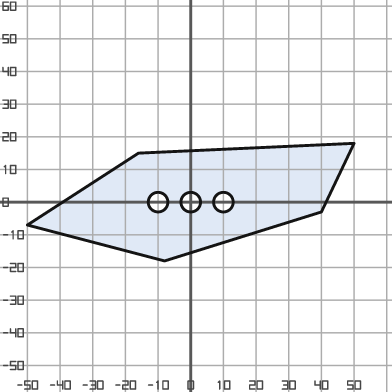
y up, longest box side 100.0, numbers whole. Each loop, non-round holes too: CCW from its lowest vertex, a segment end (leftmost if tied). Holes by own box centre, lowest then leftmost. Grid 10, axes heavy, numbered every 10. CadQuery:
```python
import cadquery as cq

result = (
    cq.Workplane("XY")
    .moveTo(-8.0, -18.0)
    .lineTo(40.0, -3.0)
    .lineTo(50.0, 18.0)
    .lineTo(-16.0, 15.0)
    .lineTo(-50.0, -7.0)
    .close()
    .moveTo(-10.0, 0.0)
    .circle(3.0)
    .moveTo(0.0, 0.0)
    .circle(3.0)
    .moveTo(10.0, 0.0)
    .circle(3.0)
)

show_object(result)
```